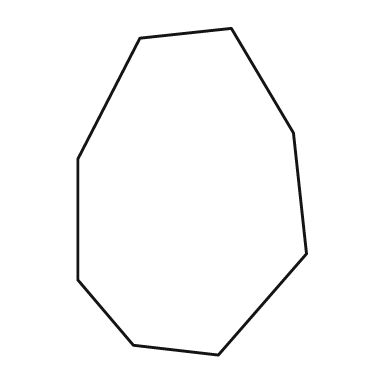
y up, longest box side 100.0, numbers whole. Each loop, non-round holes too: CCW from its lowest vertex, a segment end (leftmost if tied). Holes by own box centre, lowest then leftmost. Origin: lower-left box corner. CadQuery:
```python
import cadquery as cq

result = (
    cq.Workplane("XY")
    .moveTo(43.0, 0.0)
    .lineTo(70.0, 31.0)
    .lineTo(66.0, 68.0)
    .lineTo(47.0, 100.0)
    .lineTo(19.0, 97.0)
    .lineTo(0.0, 60.0)
    .lineTo(0.0, 23.0)
    .lineTo(17.0, 3.0)
    .close()
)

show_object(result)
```